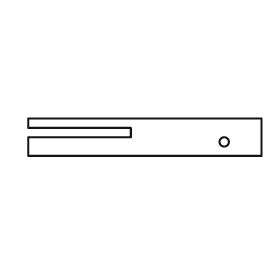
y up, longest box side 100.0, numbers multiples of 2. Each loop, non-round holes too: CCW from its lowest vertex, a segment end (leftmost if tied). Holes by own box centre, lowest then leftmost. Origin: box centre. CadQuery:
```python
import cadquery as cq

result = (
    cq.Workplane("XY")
    .moveTo(-50.0, -8.0)
    .lineTo(50.0, -8.0)
    .lineTo(50.0, 8.0)
    .lineTo(-50.0, 8.0)
    .lineTo(-50.0, 4.0)
    .lineTo(-6.0, 4.0)
    .lineTo(-6.0, 0.0)
    .lineTo(-50.0, 0.0)
    .close()
    .moveTo(34.0, -2.0)
    .circle(2.0)
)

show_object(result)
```